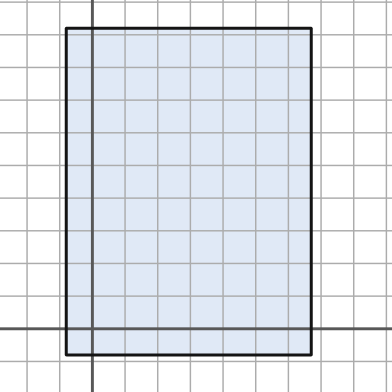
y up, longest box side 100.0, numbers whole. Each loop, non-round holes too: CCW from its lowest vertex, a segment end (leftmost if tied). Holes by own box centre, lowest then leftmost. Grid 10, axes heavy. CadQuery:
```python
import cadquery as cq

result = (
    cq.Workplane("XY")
    .moveTo(-8.0, -8.0)
    .lineTo(67.0, -8.0)
    .lineTo(67.0, 92.0)
    .lineTo(-8.0, 92.0)
    .close()
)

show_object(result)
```